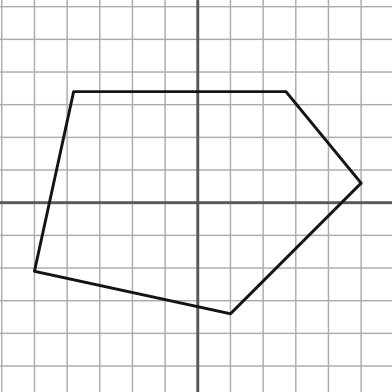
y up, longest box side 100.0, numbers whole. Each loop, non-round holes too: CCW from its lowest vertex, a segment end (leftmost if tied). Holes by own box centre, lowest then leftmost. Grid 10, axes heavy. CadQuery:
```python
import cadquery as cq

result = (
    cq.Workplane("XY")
    .moveTo(10.0, -34.0)
    .lineTo(50.0, 6.0)
    .lineTo(27.0, 34.0)
    .lineTo(-38.0, 34.0)
    .lineTo(-50.0, -21.0)
    .close()
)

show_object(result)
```